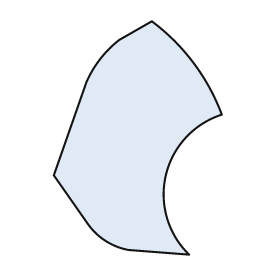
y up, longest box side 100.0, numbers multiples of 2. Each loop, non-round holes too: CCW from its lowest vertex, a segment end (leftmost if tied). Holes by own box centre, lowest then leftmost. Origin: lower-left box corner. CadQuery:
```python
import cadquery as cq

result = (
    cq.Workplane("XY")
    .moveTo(58.0, 0.0)
    .threePointArc((48.0, 34.0), (72.0, 60.0))
    .threePointArc((60.0, 82.0), (42.0, 100.0))
    .lineTo(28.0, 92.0)
    .threePointArc((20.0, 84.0), (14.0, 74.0))
    .lineTo(0.0, 34.0)
    .lineTo(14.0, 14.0)
    .threePointArc((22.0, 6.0), (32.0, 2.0))
    .close()
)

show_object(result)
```